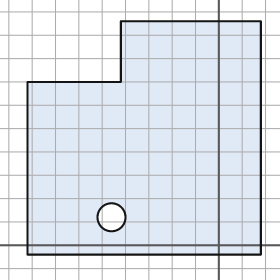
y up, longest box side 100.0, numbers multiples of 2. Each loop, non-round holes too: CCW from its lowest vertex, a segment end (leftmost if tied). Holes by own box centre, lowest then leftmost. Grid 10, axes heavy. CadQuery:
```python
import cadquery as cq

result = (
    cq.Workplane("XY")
    .moveTo(-82.0, -4.0)
    .lineTo(18.0, -4.0)
    .lineTo(18.0, 96.0)
    .lineTo(-42.0, 96.0)
    .lineTo(-42.0, 70.0)
    .lineTo(-82.0, 70.0)
    .close()
    .moveTo(-46.0, 12.0)
    .circle(6.0)
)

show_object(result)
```